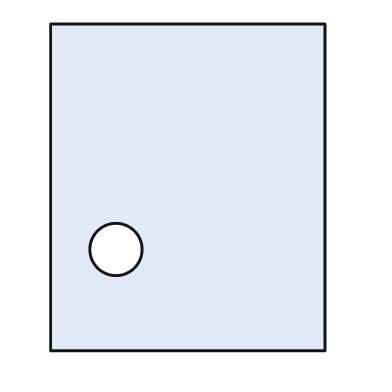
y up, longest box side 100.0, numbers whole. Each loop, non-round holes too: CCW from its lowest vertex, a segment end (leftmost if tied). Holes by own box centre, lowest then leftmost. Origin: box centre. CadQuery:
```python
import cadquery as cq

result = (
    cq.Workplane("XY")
    .moveTo(-42.0, -50.0)
    .lineTo(42.0, -50.0)
    .lineTo(42.0, 50.0)
    .lineTo(-42.0, 50.0)
    .close()
    .moveTo(-22.0, -19.0)
    .circle(8.0)
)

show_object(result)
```